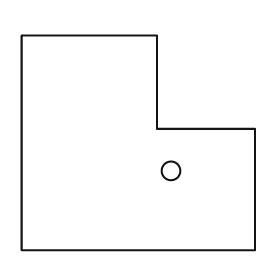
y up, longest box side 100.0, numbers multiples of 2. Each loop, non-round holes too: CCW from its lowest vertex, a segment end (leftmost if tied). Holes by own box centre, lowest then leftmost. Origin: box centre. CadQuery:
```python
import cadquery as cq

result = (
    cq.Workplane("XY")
    .moveTo(-50.0, -46.0)
    .lineTo(50.0, -46.0)
    .lineTo(50.0, 6.0)
    .lineTo(8.0, 6.0)
    .lineTo(8.0, 46.0)
    .lineTo(-50.0, 46.0)
    .close()
    .moveTo(14.0, -12.0)
    .circle(4.0)
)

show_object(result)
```